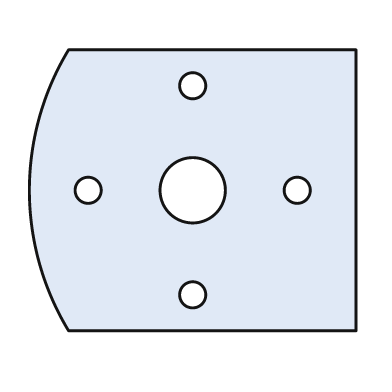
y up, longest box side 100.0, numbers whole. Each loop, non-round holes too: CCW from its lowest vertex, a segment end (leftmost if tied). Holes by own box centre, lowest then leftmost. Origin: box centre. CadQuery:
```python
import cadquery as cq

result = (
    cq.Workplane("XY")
    .moveTo(-38.0, -43.0)
    .lineTo(50.0, -43.0)
    .lineTo(50.0, 43.0)
    .lineTo(-38.0, 43.0)
    .threePointArc((-50.0, 0.0), (-38.0, -43.0))
    .close()
    .moveTo(0.0, -32.0)
    .circle(4.0)
    .moveTo(-32.0, 0.0)
    .circle(4.0)
    .moveTo(0.0, 0.0)
    .circle(10.0)
    .moveTo(32.0, 0.0)
    .circle(4.0)
    .moveTo(0.0, 32.0)
    .circle(4.0)
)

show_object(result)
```